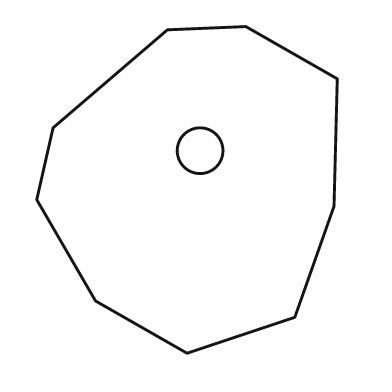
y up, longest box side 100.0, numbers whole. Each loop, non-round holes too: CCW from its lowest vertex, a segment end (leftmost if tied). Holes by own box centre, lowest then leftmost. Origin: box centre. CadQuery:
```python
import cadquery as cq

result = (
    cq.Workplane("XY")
    .moveTo(0.0, -50.0)
    .lineTo(33.0, -39.0)
    .lineTo(45.0, -5.0)
    .lineTo(46.0, 34.0)
    .lineTo(18.0, 50.0)
    .lineTo(-6.0, 49.0)
    .lineTo(-41.0, 19.0)
    .lineTo(-46.0, -3.0)
    .lineTo(-28.0, -34.0)
    .close()
    .moveTo(4.0, 12.0)
    .circle(7.0)
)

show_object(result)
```